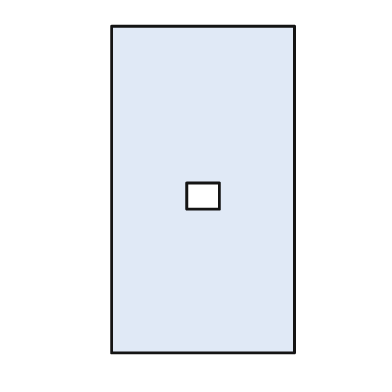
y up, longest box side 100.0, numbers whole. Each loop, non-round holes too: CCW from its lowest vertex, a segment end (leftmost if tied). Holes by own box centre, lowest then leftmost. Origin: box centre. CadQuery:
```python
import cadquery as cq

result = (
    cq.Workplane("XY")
    .moveTo(-28.0, -50.0)
    .lineTo(28.0, -50.0)
    .lineTo(28.0, 50.0)
    .lineTo(-28.0, 50.0)
    .close()
    .moveTo(-5.0, -6.0)
    .lineTo(5.0, -6.0)
    .lineTo(5.0, 2.0)
    .lineTo(-5.0, 2.0)
    .close()
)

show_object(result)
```